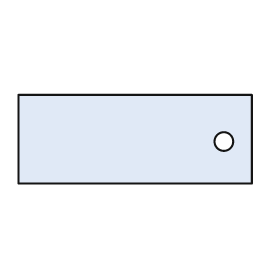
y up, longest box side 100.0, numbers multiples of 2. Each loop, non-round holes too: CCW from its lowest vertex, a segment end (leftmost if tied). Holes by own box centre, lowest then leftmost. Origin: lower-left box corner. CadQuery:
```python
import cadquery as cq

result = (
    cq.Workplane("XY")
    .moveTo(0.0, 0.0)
    .lineTo(100.0, 0.0)
    .lineTo(100.0, 38.0)
    .lineTo(0.0, 38.0)
    .close()
    .moveTo(88.0, 18.0)
    .circle(4.0)
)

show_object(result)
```